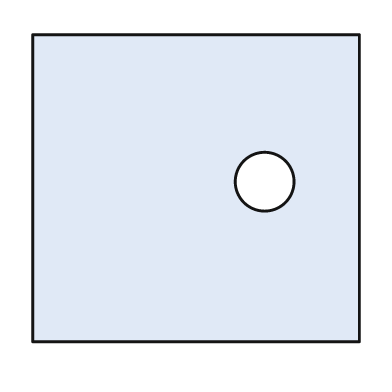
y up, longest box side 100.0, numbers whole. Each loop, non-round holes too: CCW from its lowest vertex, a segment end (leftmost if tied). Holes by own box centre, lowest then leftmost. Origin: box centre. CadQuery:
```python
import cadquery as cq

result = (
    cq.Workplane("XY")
    .moveTo(-50.0, -47.0)
    .lineTo(50.0, -47.0)
    .lineTo(50.0, 47.0)
    .lineTo(-50.0, 47.0)
    .close()
    .moveTo(21.0, 2.0)
    .circle(9.0)
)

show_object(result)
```